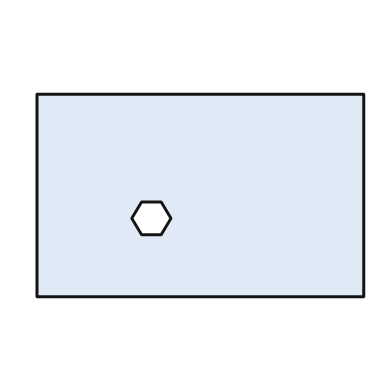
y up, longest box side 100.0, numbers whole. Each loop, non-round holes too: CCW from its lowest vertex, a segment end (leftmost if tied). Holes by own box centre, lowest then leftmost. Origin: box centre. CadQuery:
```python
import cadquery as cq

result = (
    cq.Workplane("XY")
    .moveTo(-50.0, -31.0)
    .lineTo(50.0, -31.0)
    .lineTo(50.0, 31.0)
    .lineTo(-50.0, 31.0)
    .close()
    .moveTo(-18.0, -12.0)
    .lineTo(-12.0, -12.0)
    .lineTo(-9.0, -7.0)
    .lineTo(-12.0, -2.0)
    .lineTo(-18.0, -2.0)
    .lineTo(-21.0, -7.0)
    .close()
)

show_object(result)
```